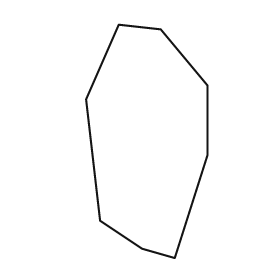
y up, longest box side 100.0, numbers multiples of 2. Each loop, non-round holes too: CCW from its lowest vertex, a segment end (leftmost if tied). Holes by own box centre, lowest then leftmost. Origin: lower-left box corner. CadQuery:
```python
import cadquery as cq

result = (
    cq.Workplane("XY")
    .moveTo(38.0, 0.0)
    .lineTo(52.0, 44.0)
    .lineTo(52.0, 74.0)
    .lineTo(32.0, 98.0)
    .lineTo(14.0, 100.0)
    .lineTo(0.0, 68.0)
    .lineTo(6.0, 16.0)
    .lineTo(24.0, 4.0)
    .close()
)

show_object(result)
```